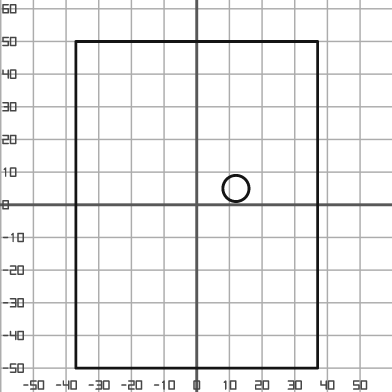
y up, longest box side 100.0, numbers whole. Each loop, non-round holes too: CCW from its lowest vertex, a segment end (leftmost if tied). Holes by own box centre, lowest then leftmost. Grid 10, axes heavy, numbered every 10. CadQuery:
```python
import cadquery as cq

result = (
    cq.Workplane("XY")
    .moveTo(-37.0, -50.0)
    .lineTo(37.0, -50.0)
    .lineTo(37.0, 50.0)
    .lineTo(-37.0, 50.0)
    .close()
    .moveTo(12.0, 5.0)
    .circle(4.0)
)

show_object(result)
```